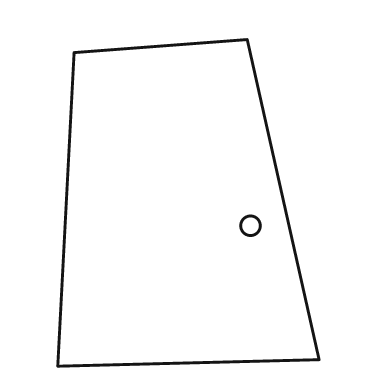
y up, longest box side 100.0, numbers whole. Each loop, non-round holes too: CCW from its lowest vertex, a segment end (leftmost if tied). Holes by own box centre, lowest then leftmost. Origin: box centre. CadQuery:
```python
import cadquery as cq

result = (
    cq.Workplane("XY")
    .moveTo(-40.0, -50.0)
    .lineTo(40.0, -48.0)
    .lineTo(18.0, 50.0)
    .lineTo(-35.0, 46.0)
    .close()
    .moveTo(19.0, -7.0)
    .circle(3.0)
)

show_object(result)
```